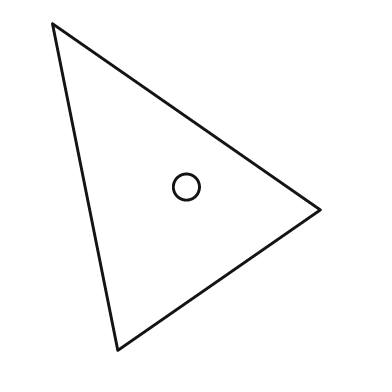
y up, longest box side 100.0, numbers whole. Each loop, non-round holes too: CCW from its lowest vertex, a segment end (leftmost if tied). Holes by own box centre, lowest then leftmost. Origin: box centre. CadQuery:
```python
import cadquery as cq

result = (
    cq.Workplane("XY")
    .moveTo(-21.0, -50.0)
    .lineTo(41.0, -7.0)
    .lineTo(-41.0, 50.0)
    .close()
    .moveTo(0.0, 0.0)
    .circle(4.0)
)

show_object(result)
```